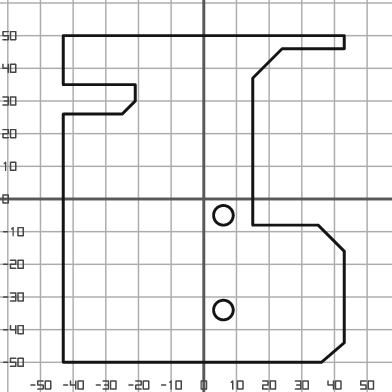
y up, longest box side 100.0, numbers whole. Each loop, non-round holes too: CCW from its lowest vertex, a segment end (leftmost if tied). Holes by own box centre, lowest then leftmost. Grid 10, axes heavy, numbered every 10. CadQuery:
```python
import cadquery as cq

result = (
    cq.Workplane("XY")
    .moveTo(-43.0, -50.0)
    .lineTo(36.0, -50.0)
    .lineTo(43.0, -44.0)
    .lineTo(43.0, -16.0)
    .lineTo(35.0, -8.0)
    .lineTo(15.0, -8.0)
    .lineTo(15.0, 37.0)
    .lineTo(24.0, 46.0)
    .lineTo(43.0, 46.0)
    .lineTo(43.0, 50.0)
    .lineTo(-43.0, 50.0)
    .lineTo(-43.0, 35.0)
    .lineTo(-21.0, 35.0)
    .lineTo(-21.0, 30.0)
    .lineTo(-25.0, 26.0)
    .lineTo(-43.0, 26.0)
    .close()
    .moveTo(6.0, -34.0)
    .circle(3.0)
    .moveTo(6.0, -5.0)
    .circle(3.0)
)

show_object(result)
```